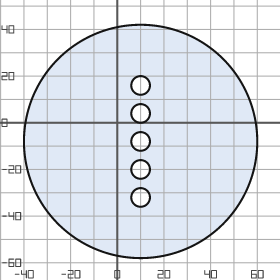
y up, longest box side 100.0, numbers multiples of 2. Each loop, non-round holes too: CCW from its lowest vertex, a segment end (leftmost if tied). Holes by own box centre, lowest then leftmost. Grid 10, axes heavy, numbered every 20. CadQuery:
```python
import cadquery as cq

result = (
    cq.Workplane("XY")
    .moveTo(10.0, -8.0)
    .circle(50.0)
    .moveTo(10.0, -32.0)
    .circle(4.0)
    .moveTo(10.0, -20.0)
    .circle(4.0)
    .moveTo(10.0, -8.0)
    .circle(4.0)
    .moveTo(10.0, 4.0)
    .circle(4.0)
    .moveTo(10.0, 16.0)
    .circle(4.0)
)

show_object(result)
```